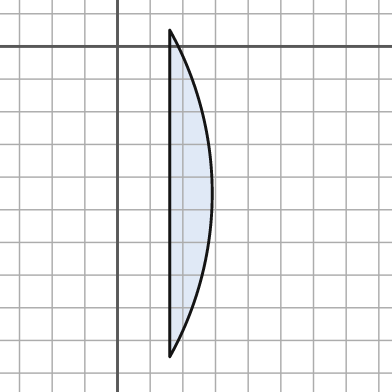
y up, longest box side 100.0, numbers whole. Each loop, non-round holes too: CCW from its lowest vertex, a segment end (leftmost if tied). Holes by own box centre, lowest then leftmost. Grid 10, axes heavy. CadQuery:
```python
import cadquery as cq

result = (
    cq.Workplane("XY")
    .moveTo(16.0, -95.0)
    .threePointArc((29.0, -45.0), (16.0, 5.0))
    .close()
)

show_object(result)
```